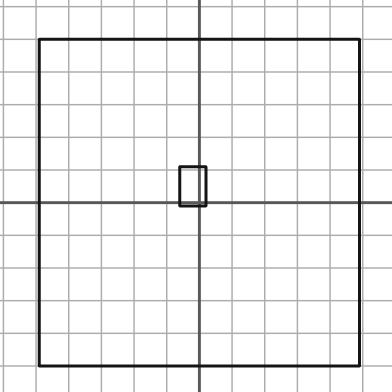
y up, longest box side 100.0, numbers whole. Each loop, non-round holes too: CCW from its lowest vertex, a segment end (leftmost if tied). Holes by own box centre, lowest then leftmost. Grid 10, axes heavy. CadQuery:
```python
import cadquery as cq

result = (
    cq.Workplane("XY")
    .moveTo(-49.0, -50.0)
    .lineTo(49.0, -50.0)
    .lineTo(49.0, 50.0)
    .lineTo(-49.0, 50.0)
    .close()
    .moveTo(-6.0, -1.0)
    .lineTo(2.0, -1.0)
    .lineTo(2.0, 11.0)
    .lineTo(-6.0, 11.0)
    .close()
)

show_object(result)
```